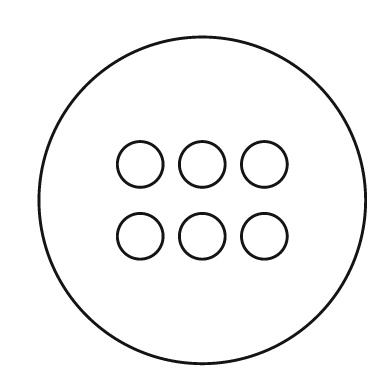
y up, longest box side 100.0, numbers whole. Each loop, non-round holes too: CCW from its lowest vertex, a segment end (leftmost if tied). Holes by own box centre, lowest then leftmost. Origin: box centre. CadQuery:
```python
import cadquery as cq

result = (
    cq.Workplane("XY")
    .moveTo(0.0, 0.0)
    .circle(50.0)
    .moveTo(-19.0, -11.0)
    .circle(7.0)
    .moveTo(0.0, -11.0)
    .circle(7.0)
    .moveTo(19.0, -11.0)
    .circle(7.0)
    .moveTo(-19.0, 11.0)
    .circle(7.0)
    .moveTo(0.0, 11.0)
    .circle(7.0)
    .moveTo(19.0, 11.0)
    .circle(7.0)
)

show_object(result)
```